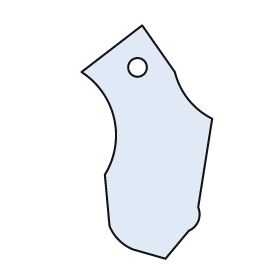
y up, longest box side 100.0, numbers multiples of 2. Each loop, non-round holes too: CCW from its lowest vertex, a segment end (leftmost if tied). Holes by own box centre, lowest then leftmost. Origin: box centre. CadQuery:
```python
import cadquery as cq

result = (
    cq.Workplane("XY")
    .moveTo(8.0, -50.0)
    .lineTo(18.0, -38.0)
    .threePointArc((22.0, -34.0), (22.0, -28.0))
    .lineTo(28.0, 10.0)
    .threePointArc((18.0, 18.0), (12.0, 30.0))
    .lineTo(-2.0, 50.0)
    .lineTo(-28.0, 30.0)
    .threePointArc((-14.0, 10.0), (-18.0, -14.0))
    .lineTo(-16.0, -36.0)
    .threePointArc((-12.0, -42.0), (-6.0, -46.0))
    .close()
    .moveTo(-4.0, 32.0)
    .circle(4.0)
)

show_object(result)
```